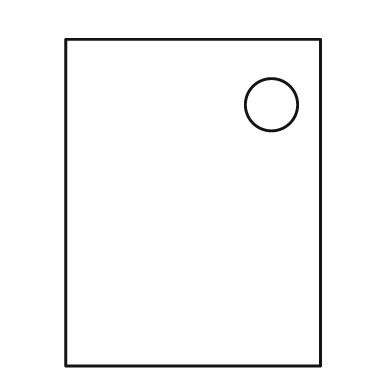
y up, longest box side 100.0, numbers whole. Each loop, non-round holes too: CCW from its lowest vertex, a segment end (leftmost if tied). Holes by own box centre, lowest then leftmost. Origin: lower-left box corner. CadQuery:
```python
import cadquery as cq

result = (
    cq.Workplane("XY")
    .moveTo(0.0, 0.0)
    .lineTo(78.0, 0.0)
    .lineTo(78.0, 100.0)
    .lineTo(0.0, 100.0)
    .close()
    .moveTo(63.0, 80.0)
    .circle(8.0)
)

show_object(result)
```